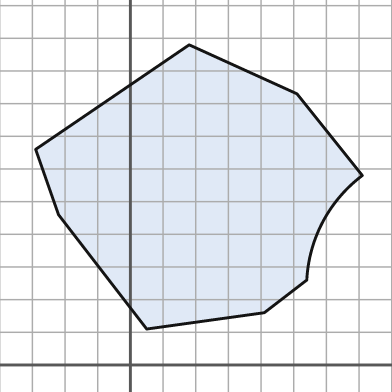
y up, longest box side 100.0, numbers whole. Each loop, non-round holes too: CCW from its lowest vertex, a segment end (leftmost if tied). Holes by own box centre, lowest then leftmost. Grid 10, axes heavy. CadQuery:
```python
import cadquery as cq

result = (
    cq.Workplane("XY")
    .moveTo(5.0, 11.0)
    .lineTo(41.0, 16.0)
    .lineTo(54.0, 26.0)
    .threePointArc((59.0, 44.0), (71.0, 58.0))
    .lineTo(51.0, 83.0)
    .lineTo(18.0, 98.0)
    .lineTo(-29.0, 66.0)
    .lineTo(-22.0, 46.0)
    .close()
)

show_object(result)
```